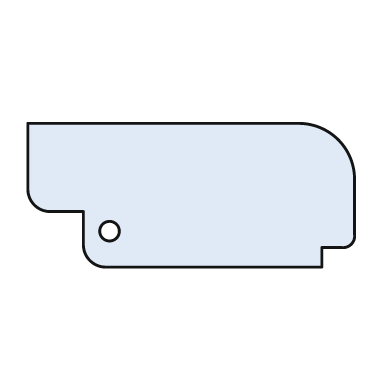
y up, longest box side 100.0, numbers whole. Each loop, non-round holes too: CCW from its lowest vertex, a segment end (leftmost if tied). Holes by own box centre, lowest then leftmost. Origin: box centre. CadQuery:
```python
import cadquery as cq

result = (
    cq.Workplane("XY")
    .moveTo(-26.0, -22.0)
    .lineTo(40.0, -22.0)
    .lineTo(40.0, -16.0)
    .lineTo(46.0, -16.0)
    .threePointArc((49.0, -15.0), (50.0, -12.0))
    .lineTo(50.0, 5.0)
    .threePointArc((45.0, 17.0), (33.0, 22.0))
    .lineTo(-50.0, 22.0)
    .lineTo(-50.0, 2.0)
    .threePointArc((-48.0, -3.0), (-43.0, -5.0))
    .lineTo(-33.0, -5.0)
    .lineTo(-33.0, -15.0)
    .threePointArc((-31.0, -20.0), (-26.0, -22.0))
    .close()
    .moveTo(-25.0, -11.0)
    .circle(3.0)
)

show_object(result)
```